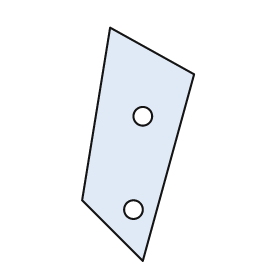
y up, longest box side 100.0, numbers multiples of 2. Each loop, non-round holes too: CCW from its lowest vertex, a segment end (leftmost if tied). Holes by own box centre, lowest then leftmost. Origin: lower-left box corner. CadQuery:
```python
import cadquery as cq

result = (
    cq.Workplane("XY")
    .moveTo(26.0, 0.0)
    .lineTo(48.0, 80.0)
    .lineTo(12.0, 100.0)
    .lineTo(0.0, 26.0)
    .close()
    .moveTo(22.0, 22.0)
    .circle(4.0)
    .moveTo(26.0, 62.0)
    .circle(4.0)
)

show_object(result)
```